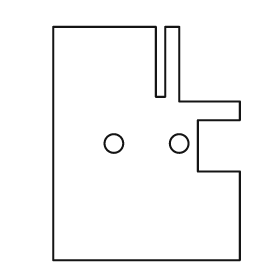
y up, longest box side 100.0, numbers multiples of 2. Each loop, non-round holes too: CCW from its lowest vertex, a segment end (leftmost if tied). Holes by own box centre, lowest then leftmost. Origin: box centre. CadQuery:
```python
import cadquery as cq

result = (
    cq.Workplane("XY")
    .moveTo(-40.0, -50.0)
    .lineTo(40.0, -50.0)
    .lineTo(40.0, -12.0)
    .lineTo(22.0, -12.0)
    .lineTo(22.0, 10.0)
    .lineTo(40.0, 10.0)
    .lineTo(40.0, 18.0)
    .lineTo(14.0, 18.0)
    .lineTo(14.0, 50.0)
    .lineTo(8.0, 50.0)
    .lineTo(8.0, 20.0)
    .lineTo(4.0, 20.0)
    .lineTo(4.0, 50.0)
    .lineTo(-40.0, 50.0)
    .close()
    .moveTo(-14.0, 0.0)
    .circle(4.0)
    .moveTo(14.0, 0.0)
    .circle(4.0)
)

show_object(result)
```